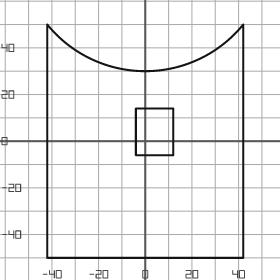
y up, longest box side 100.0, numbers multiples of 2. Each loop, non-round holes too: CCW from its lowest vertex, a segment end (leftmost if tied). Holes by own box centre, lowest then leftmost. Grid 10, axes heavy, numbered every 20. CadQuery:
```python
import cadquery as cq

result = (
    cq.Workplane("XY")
    .moveTo(-42.0, -50.0)
    .lineTo(42.0, -50.0)
    .lineTo(42.0, 50.0)
    .threePointArc((0.0, 30.0), (-42.0, 50.0))
    .close()
    .moveTo(-4.0, -6.0)
    .lineTo(12.0, -6.0)
    .lineTo(12.0, 14.0)
    .lineTo(-4.0, 14.0)
    .close()
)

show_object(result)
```